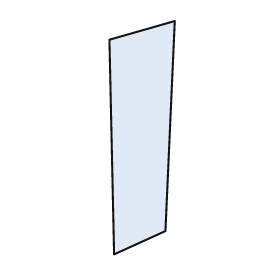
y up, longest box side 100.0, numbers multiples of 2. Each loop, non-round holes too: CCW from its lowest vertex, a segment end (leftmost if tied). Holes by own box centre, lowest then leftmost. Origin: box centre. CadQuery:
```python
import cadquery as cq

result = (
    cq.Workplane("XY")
    .moveTo(-12.0, -50.0)
    .lineTo(10.0, -40.0)
    .lineTo(14.0, 50.0)
    .lineTo(-14.0, 42.0)
    .close()
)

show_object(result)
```